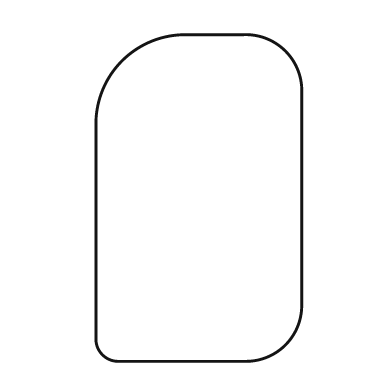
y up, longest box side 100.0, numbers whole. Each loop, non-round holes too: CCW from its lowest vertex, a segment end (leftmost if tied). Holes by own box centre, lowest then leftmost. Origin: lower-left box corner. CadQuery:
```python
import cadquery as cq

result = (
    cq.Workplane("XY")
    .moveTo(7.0, 0.0)
    .lineTo(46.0, 0.0)
    .threePointArc((58.0, 5.0), (63.0, 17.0))
    .lineTo(63.0, 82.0)
    .threePointArc((58.0, 95.0), (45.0, 100.0))
    .lineTo(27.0, 100.0)
    .threePointArc((8.0, 92.0), (0.0, 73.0))
    .lineTo(0.0, 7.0)
    .threePointArc((2.0, 2.0), (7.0, 0.0))
    .close()
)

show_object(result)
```